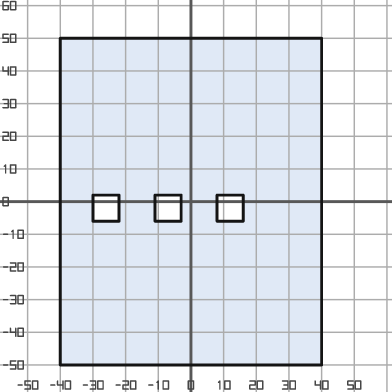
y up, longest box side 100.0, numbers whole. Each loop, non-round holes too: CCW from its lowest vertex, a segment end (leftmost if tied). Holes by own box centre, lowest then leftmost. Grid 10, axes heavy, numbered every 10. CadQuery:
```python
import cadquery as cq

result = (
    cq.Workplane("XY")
    .moveTo(-40.0, -50.0)
    .lineTo(40.0, -50.0)
    .lineTo(40.0, 50.0)
    .lineTo(-40.0, 50.0)
    .close()
    .moveTo(-30.0, -6.0)
    .lineTo(-22.0, -6.0)
    .lineTo(-22.0, 2.0)
    .lineTo(-30.0, 2.0)
    .close()
    .moveTo(-11.0, -6.0)
    .lineTo(-3.0, -6.0)
    .lineTo(-3.0, 2.0)
    .lineTo(-11.0, 2.0)
    .close()
    .moveTo(8.0, -6.0)
    .lineTo(16.0, -6.0)
    .lineTo(16.0, 2.0)
    .lineTo(8.0, 2.0)
    .close()
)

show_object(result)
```